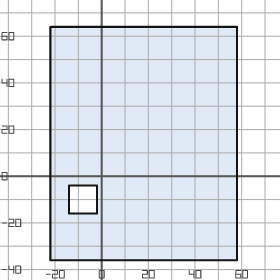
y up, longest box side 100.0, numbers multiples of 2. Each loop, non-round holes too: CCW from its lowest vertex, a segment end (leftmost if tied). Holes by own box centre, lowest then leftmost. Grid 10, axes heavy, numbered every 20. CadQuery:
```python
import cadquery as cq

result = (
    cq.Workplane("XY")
    .moveTo(-22.0, -36.0)
    .lineTo(58.0, -36.0)
    .lineTo(58.0, 64.0)
    .lineTo(-22.0, 64.0)
    .close()
    .moveTo(-14.0, -16.0)
    .lineTo(-2.0, -16.0)
    .lineTo(-2.0, -4.0)
    .lineTo(-14.0, -4.0)
    .close()
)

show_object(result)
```